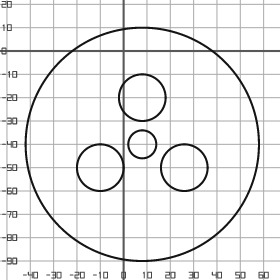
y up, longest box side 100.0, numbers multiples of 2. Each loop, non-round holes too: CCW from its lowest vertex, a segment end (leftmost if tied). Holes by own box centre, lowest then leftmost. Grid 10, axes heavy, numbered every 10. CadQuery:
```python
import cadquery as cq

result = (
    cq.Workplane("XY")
    .moveTo(8.0, -40.0)
    .circle(50.0)
    .moveTo(-10.0, -50.0)
    .circle(10.0)
    .moveTo(26.0, -50.0)
    .circle(10.0)
    .moveTo(8.0, -40.0)
    .circle(6.0)
    .moveTo(8.0, -20.0)
    .circle(10.0)
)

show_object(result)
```